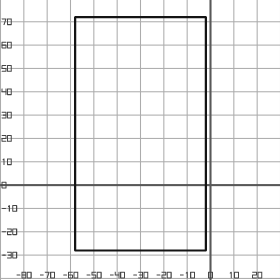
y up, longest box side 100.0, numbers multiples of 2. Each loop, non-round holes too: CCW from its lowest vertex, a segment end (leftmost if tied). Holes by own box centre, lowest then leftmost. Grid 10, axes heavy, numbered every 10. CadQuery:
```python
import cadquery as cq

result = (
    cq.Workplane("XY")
    .moveTo(-58.0, -28.0)
    .lineTo(-2.0, -28.0)
    .lineTo(-2.0, 72.0)
    .lineTo(-58.0, 72.0)
    .close()
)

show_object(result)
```